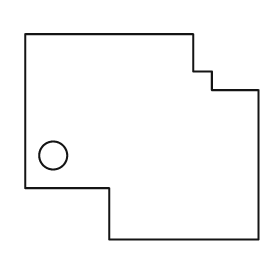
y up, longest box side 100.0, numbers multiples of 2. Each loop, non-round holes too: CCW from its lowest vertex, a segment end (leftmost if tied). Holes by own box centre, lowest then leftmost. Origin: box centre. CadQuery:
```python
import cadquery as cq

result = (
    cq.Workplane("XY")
    .moveTo(-14.0, -44.0)
    .lineTo(50.0, -44.0)
    .lineTo(50.0, 20.0)
    .lineTo(30.0, 20.0)
    .lineTo(30.0, 28.0)
    .lineTo(22.0, 28.0)
    .lineTo(22.0, 44.0)
    .lineTo(-50.0, 44.0)
    .lineTo(-50.0, -22.0)
    .lineTo(-14.0, -22.0)
    .close()
    .moveTo(-38.0, -8.0)
    .circle(6.0)
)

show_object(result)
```